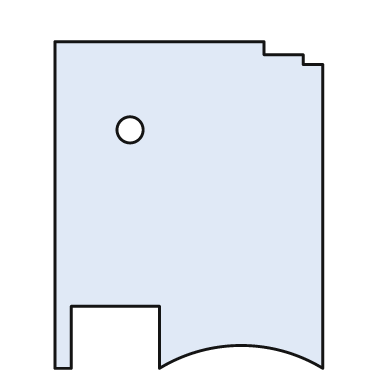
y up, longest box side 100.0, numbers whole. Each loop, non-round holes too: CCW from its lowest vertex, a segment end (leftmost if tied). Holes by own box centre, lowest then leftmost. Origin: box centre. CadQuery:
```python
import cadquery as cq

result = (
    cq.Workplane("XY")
    .moveTo(-41.0, -50.0)
    .lineTo(-36.0, -50.0)
    .lineTo(-36.0, -31.0)
    .lineTo(-9.0, -31.0)
    .lineTo(-9.0, -50.0)
    .threePointArc((16.0, -43.0), (41.0, -50.0))
    .lineTo(41.0, 43.0)
    .lineTo(35.0, 43.0)
    .lineTo(35.0, 46.0)
    .lineTo(23.0, 46.0)
    .lineTo(23.0, 50.0)
    .lineTo(-41.0, 50.0)
    .close()
    .moveTo(-18.0, 23.0)
    .circle(4.0)
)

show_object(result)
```